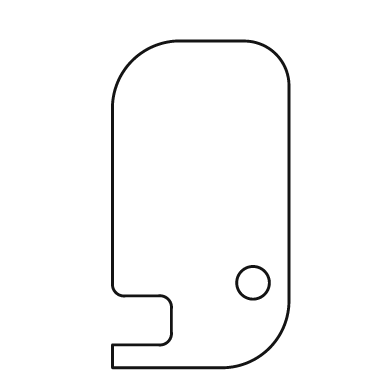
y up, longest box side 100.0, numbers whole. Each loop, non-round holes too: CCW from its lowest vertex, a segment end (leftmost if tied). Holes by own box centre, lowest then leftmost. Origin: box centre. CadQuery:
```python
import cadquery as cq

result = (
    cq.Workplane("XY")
    .moveTo(-27.0, -50.0)
    .lineTo(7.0, -50.0)
    .threePointArc((21.0, -44.0), (27.0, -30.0))
    .lineTo(27.0, 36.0)
    .threePointArc((23.0, 46.0), (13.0, 50.0))
    .lineTo(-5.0, 50.0)
    .threePointArc((-21.0, 44.0), (-27.0, 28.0))
    .lineTo(-27.0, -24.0)
    .threePointArc((-26.0, -27.0), (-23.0, -28.0))
    .lineTo(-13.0, -28.0)
    .threePointArc((-10.0, -29.0), (-9.0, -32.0))
    .lineTo(-9.0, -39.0)
    .threePointArc((-10.0, -42.0), (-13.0, -43.0))
    .lineTo(-27.0, -43.0)
    .close()
    .moveTo(16.0, -24.0)
    .circle(5.0)
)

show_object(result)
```